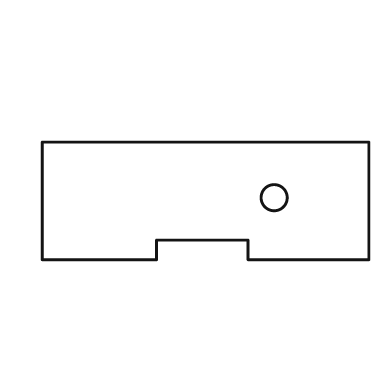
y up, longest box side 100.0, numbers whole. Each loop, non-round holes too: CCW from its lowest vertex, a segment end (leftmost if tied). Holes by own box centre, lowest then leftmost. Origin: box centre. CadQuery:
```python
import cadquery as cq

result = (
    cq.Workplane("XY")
    .moveTo(-50.0, -18.0)
    .lineTo(-15.0, -18.0)
    .lineTo(-15.0, -12.0)
    .lineTo(13.0, -12.0)
    .lineTo(13.0, -18.0)
    .lineTo(50.0, -18.0)
    .lineTo(50.0, 18.0)
    .lineTo(-50.0, 18.0)
    .close()
    .moveTo(21.0, 1.0)
    .circle(4.0)
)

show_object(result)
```